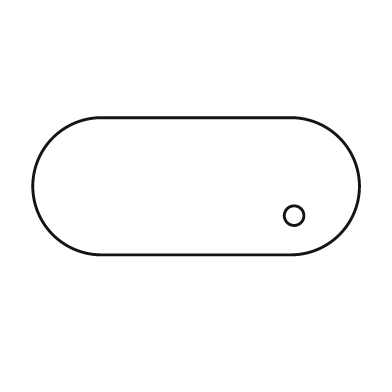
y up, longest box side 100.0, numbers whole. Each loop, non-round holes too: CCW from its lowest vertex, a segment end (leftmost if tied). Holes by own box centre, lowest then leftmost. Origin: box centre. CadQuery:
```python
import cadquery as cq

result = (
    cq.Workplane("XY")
    .moveTo(-29.0, -21.0)
    .lineTo(29.0, -21.0)
    .threePointArc((50.0, 0.0), (29.0, 21.0))
    .lineTo(-29.0, 21.0)
    .threePointArc((-50.0, 0.0), (-29.0, -21.0))
    .close()
    .moveTo(30.0, -9.0)
    .circle(3.0)
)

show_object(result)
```